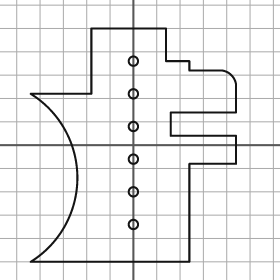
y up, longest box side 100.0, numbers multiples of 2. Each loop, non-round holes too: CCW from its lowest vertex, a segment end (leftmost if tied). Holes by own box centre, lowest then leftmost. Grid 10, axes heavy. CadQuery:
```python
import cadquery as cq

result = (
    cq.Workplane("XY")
    .moveTo(-44.0, -50.0)
    .lineTo(24.0, -50.0)
    .lineTo(24.0, -8.0)
    .lineTo(44.0, -8.0)
    .lineTo(44.0, 4.0)
    .lineTo(16.0, 4.0)
    .lineTo(16.0, 14.0)
    .lineTo(44.0, 14.0)
    .lineTo(44.0, 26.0)
    .threePointArc((42.0, 30.0), (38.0, 32.0))
    .lineTo(24.0, 32.0)
    .lineTo(24.0, 36.0)
    .lineTo(14.0, 36.0)
    .lineTo(14.0, 50.0)
    .lineTo(-18.0, 50.0)
    .lineTo(-18.0, 22.0)
    .lineTo(-44.0, 22.0)
    .threePointArc((-24.0, -14.0), (-44.0, -50.0))
    .close()
    .moveTo(0.0, -34.0)
    .circle(2.0)
    .moveTo(0.0, -20.0)
    .circle(2.0)
    .moveTo(0.0, -6.0)
    .circle(2.0)
    .moveTo(0.0, 8.0)
    .circle(2.0)
    .moveTo(0.0, 22.0)
    .circle(2.0)
    .moveTo(0.0, 36.0)
    .circle(2.0)
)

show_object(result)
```